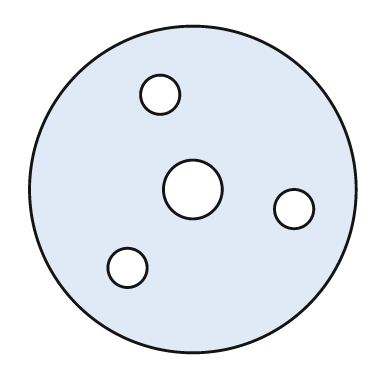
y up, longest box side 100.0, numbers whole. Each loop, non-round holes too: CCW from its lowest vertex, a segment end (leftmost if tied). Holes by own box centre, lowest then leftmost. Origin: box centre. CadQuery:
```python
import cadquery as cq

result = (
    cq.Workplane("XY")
    .moveTo(0.0, 0.0)
    .circle(50.0)
    .moveTo(-20.0, -24.0)
    .circle(6.0)
    .moveTo(31.0, -6.0)
    .circle(6.0)
    .moveTo(0.0, 0.0)
    .circle(9.0)
    .moveTo(-10.0, 29.0)
    .circle(6.0)
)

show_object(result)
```